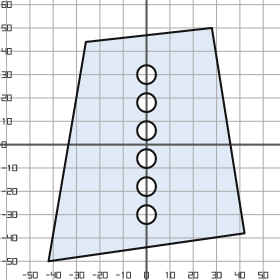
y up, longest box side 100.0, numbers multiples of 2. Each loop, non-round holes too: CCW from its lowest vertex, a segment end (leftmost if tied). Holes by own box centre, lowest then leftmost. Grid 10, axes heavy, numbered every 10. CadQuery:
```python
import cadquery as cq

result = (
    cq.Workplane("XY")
    .moveTo(-42.0, -50.0)
    .lineTo(42.0, -38.0)
    .lineTo(28.0, 50.0)
    .lineTo(-26.0, 44.0)
    .close()
    .moveTo(0.0, -30.0)
    .circle(4.0)
    .moveTo(0.0, -18.0)
    .circle(4.0)
    .moveTo(0.0, -6.0)
    .circle(4.0)
    .moveTo(0.0, 6.0)
    .circle(4.0)
    .moveTo(0.0, 18.0)
    .circle(4.0)
    .moveTo(0.0, 30.0)
    .circle(4.0)
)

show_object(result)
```